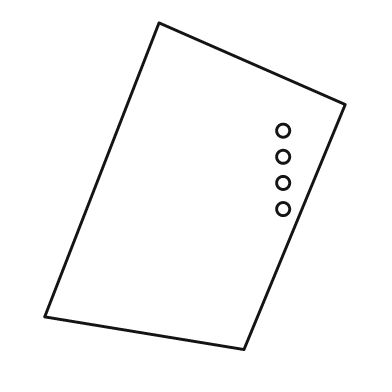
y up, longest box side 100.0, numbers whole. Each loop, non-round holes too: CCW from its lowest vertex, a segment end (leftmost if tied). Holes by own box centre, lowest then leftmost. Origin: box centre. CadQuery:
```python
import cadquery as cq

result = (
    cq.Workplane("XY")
    .moveTo(15.0, -50.0)
    .lineTo(46.0, 25.0)
    .lineTo(-11.0, 50.0)
    .lineTo(-46.0, -40.0)
    .close()
    .moveTo(27.0, -7.0)
    .circle(2.0)
    .moveTo(27.0, 1.0)
    .circle(2.0)
    .moveTo(27.0, 9.0)
    .circle(2.0)
    .moveTo(27.0, 17.0)
    .circle(2.0)
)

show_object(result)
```